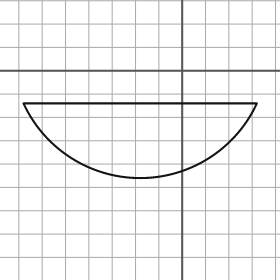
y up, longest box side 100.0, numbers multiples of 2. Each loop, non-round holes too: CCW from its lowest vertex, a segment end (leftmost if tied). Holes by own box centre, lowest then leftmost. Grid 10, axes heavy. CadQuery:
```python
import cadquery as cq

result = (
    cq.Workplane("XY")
    .moveTo(-68.0, -14.0)
    .threePointArc((-18.0, -46.0), (32.0, -14.0))
    .close()
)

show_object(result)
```